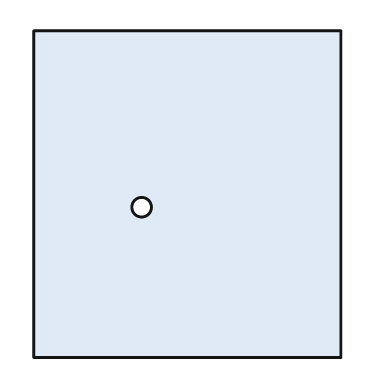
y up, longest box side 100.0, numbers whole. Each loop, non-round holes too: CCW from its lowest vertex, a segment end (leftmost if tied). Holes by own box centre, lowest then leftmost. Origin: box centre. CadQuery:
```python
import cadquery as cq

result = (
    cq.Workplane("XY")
    .moveTo(-47.0, -50.0)
    .lineTo(47.0, -50.0)
    .lineTo(47.0, 50.0)
    .lineTo(-47.0, 50.0)
    .close()
    .moveTo(-14.0, -4.0)
    .circle(3.0)
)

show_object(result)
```